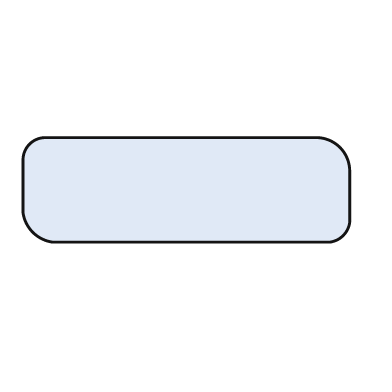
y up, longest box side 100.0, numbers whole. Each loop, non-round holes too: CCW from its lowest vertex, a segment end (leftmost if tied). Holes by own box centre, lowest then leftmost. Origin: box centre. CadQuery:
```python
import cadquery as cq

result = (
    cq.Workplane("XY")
    .moveTo(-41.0, -16.0)
    .lineTo(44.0, -16.0)
    .threePointArc((48.0, -14.0), (50.0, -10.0))
    .lineTo(50.0, 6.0)
    .threePointArc((47.0, 13.0), (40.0, 16.0))
    .lineTo(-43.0, 16.0)
    .threePointArc((-48.0, 14.0), (-50.0, 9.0))
    .lineTo(-50.0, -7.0)
    .threePointArc((-47.0, -13.0), (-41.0, -16.0))
    .close()
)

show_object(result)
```